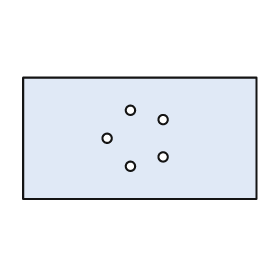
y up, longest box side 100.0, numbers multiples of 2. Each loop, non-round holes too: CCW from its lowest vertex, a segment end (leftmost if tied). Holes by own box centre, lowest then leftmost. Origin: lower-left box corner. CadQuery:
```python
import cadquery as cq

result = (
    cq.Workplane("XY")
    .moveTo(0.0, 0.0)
    .lineTo(100.0, 0.0)
    .lineTo(100.0, 52.0)
    .lineTo(0.0, 52.0)
    .close()
    .moveTo(46.0, 14.0)
    .circle(2.0)
    .moveTo(60.0, 18.0)
    .circle(2.0)
    .moveTo(36.0, 26.0)
    .circle(2.0)
    .moveTo(60.0, 34.0)
    .circle(2.0)
    .moveTo(46.0, 38.0)
    .circle(2.0)
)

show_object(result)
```